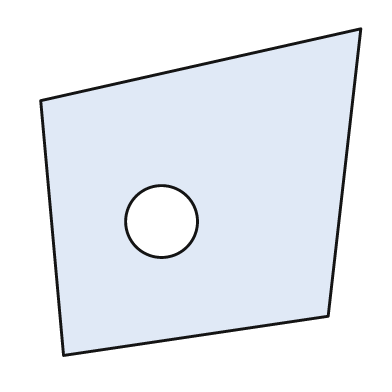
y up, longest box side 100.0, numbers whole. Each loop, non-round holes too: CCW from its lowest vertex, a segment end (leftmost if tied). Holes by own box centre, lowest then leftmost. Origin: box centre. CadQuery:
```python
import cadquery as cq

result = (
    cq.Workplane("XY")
    .moveTo(-42.0, -50.0)
    .lineTo(39.0, -38.0)
    .lineTo(49.0, 50.0)
    .lineTo(-49.0, 28.0)
    .close()
    .moveTo(-12.0, -9.0)
    .circle(11.0)
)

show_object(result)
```